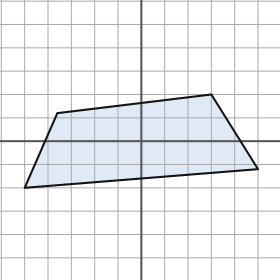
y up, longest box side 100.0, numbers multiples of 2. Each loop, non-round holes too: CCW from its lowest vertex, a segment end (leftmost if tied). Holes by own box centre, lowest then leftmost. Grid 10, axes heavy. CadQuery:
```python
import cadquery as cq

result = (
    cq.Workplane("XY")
    .moveTo(-50.0, -20.0)
    .lineTo(50.0, -12.0)
    .lineTo(30.0, 20.0)
    .lineTo(-36.0, 12.0)
    .close()
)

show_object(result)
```